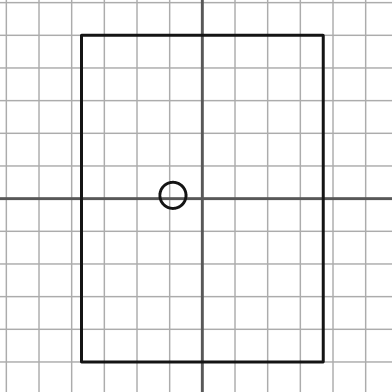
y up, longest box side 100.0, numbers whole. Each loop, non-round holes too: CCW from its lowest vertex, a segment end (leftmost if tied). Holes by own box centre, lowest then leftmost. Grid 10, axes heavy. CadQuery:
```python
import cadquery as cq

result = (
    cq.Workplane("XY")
    .moveTo(-37.0, -50.0)
    .lineTo(37.0, -50.0)
    .lineTo(37.0, 50.0)
    .lineTo(-37.0, 50.0)
    .close()
    .moveTo(-9.0, 1.0)
    .circle(4.0)
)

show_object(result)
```